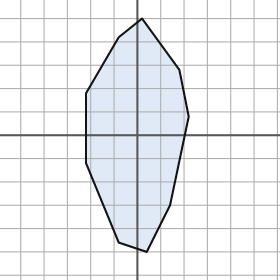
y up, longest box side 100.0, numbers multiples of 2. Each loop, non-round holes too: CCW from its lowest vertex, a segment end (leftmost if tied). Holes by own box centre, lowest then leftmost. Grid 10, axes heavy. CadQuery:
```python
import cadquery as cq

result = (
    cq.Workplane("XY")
    .moveTo(4.0, -50.0)
    .lineTo(14.0, -30.0)
    .lineTo(22.0, 8.0)
    .lineTo(18.0, 28.0)
    .lineTo(2.0, 50.0)
    .lineTo(-8.0, 42.0)
    .lineTo(-22.0, 18.0)
    .lineTo(-22.0, -12.0)
    .lineTo(-8.0, -46.0)
    .close()
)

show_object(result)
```